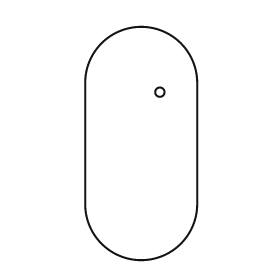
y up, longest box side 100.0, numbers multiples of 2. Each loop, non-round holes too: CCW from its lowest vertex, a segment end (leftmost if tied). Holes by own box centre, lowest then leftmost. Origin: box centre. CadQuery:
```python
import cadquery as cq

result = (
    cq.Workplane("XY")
    .moveTo(-24.0, -26.0)
    .threePointArc((0.0, -50.0), (24.0, -26.0))
    .lineTo(24.0, 26.0)
    .threePointArc((0.0, 50.0), (-24.0, 26.0))
    .close()
    .moveTo(8.0, 22.0)
    .circle(2.0)
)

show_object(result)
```